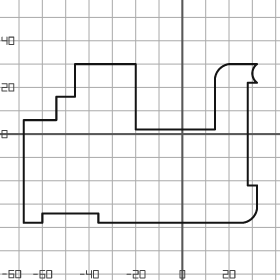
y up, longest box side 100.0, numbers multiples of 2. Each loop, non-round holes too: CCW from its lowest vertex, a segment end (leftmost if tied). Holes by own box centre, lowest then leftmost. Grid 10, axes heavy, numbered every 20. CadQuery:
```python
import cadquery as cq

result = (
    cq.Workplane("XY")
    .moveTo(-68.0, -38.0)
    .lineTo(-60.0, -38.0)
    .lineTo(-60.0, -34.0)
    .lineTo(-36.0, -34.0)
    .lineTo(-36.0, -38.0)
    .lineTo(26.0, -38.0)
    .threePointArc((30.0, -36.0), (32.0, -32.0))
    .lineTo(32.0, -22.0)
    .lineTo(28.0, -22.0)
    .lineTo(28.0, 22.0)
    .lineTo(32.0, 22.0)
    .threePointArc((30.0, 26.0), (32.0, 30.0))
    .lineTo(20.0, 30.0)
    .threePointArc((16.0, 28.0), (14.0, 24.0))
    .lineTo(14.0, 2.0)
    .lineTo(-20.0, 2.0)
    .lineTo(-20.0, 30.0)
    .lineTo(-46.0, 30.0)
    .lineTo(-46.0, 16.0)
    .lineTo(-54.0, 16.0)
    .lineTo(-54.0, 6.0)
    .lineTo(-68.0, 6.0)
    .close()
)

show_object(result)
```